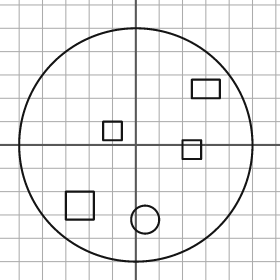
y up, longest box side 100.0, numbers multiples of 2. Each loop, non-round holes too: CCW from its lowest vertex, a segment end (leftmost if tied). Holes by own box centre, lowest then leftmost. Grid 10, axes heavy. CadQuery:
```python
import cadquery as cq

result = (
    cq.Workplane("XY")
    .moveTo(0.0, 0.0)
    .circle(50.0)
    .moveTo(4.0, -32.0)
    .circle(6.0)
    .moveTo(-30.0, -32.0)
    .lineTo(-18.0, -32.0)
    .lineTo(-18.0, -20.0)
    .lineTo(-30.0, -20.0)
    .close()
    .moveTo(20.0, -6.0)
    .lineTo(28.0, -6.0)
    .lineTo(28.0, 2.0)
    .lineTo(20.0, 2.0)
    .close()
    .moveTo(-14.0, 2.0)
    .lineTo(-6.0, 2.0)
    .lineTo(-6.0, 10.0)
    .lineTo(-14.0, 10.0)
    .close()
    .moveTo(24.0, 20.0)
    .lineTo(36.0, 20.0)
    .lineTo(36.0, 28.0)
    .lineTo(24.0, 28.0)
    .close()
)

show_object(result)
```